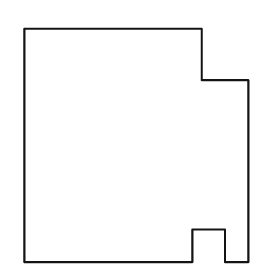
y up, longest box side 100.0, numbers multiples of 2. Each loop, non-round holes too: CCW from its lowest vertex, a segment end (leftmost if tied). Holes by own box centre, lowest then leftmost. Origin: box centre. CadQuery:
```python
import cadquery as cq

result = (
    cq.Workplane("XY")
    .moveTo(-48.0, -50.0)
    .lineTo(24.0, -50.0)
    .lineTo(24.0, -36.0)
    .lineTo(38.0, -36.0)
    .lineTo(38.0, -50.0)
    .lineTo(48.0, -50.0)
    .lineTo(48.0, 28.0)
    .lineTo(28.0, 28.0)
    .lineTo(28.0, 50.0)
    .lineTo(-48.0, 50.0)
    .close()
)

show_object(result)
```